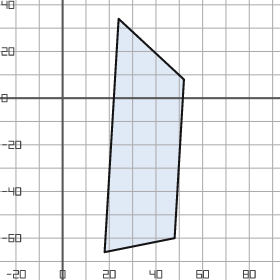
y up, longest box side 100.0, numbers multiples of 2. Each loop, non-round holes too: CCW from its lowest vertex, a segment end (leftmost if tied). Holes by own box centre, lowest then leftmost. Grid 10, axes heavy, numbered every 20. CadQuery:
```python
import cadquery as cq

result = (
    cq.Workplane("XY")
    .moveTo(18.0, -66.0)
    .lineTo(48.0, -60.0)
    .lineTo(52.0, 8.0)
    .lineTo(24.0, 34.0)
    .close()
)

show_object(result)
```